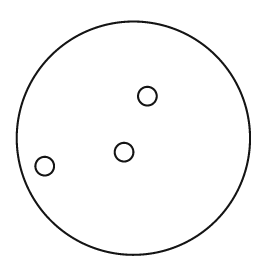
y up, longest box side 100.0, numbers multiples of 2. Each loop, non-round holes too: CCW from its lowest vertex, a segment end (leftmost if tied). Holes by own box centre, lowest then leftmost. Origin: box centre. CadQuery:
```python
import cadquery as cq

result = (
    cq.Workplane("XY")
    .moveTo(0.0, 0.0)
    .circle(50.0)
    .moveTo(-38.0, -12.0)
    .circle(4.0)
    .moveTo(-4.0, -6.0)
    .circle(4.0)
    .moveTo(6.0, 18.0)
    .circle(4.0)
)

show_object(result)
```